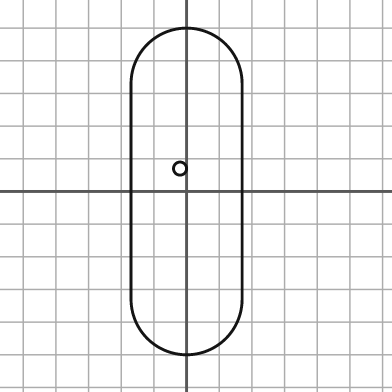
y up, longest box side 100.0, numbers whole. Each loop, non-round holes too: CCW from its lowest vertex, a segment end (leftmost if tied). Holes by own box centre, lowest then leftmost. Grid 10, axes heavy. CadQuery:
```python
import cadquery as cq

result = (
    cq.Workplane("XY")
    .moveTo(-17.0, -33.0)
    .threePointArc((0.0, -50.0), (17.0, -33.0))
    .lineTo(17.0, 33.0)
    .threePointArc((0.0, 50.0), (-17.0, 33.0))
    .close()
    .moveTo(-2.0, 7.0)
    .circle(2.0)
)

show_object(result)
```